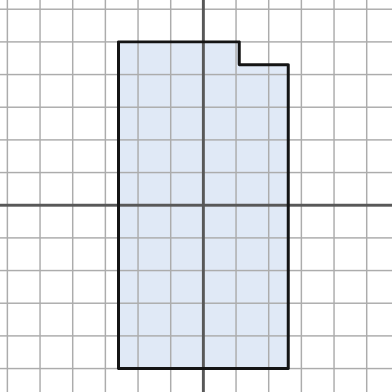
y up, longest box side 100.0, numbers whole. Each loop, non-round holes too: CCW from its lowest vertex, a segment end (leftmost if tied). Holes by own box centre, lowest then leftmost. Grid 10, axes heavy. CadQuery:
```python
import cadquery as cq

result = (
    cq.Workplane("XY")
    .moveTo(-26.0, -50.0)
    .lineTo(26.0, -50.0)
    .lineTo(26.0, 43.0)
    .lineTo(11.0, 43.0)
    .lineTo(11.0, 50.0)
    .lineTo(-26.0, 50.0)
    .close()
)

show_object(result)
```